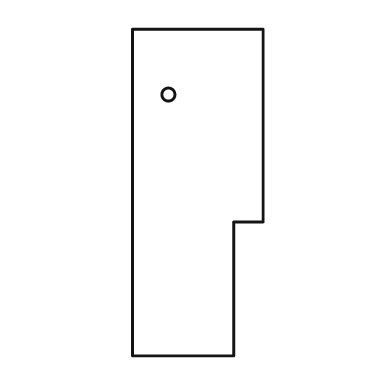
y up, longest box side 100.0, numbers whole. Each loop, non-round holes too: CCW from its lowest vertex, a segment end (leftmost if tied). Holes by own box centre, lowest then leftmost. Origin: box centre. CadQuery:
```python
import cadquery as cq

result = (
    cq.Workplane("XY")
    .moveTo(-20.0, -50.0)
    .lineTo(11.0, -50.0)
    .lineTo(11.0, -9.0)
    .lineTo(20.0, -9.0)
    .lineTo(20.0, 50.0)
    .lineTo(-20.0, 50.0)
    .close()
    .moveTo(-9.0, 30.0)
    .circle(2.0)
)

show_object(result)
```